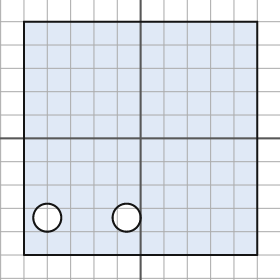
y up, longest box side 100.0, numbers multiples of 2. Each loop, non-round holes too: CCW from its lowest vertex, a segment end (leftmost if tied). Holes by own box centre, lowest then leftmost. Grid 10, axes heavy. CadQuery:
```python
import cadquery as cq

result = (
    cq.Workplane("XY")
    .moveTo(-50.0, -50.0)
    .lineTo(50.0, -50.0)
    .lineTo(50.0, 50.0)
    .lineTo(-50.0, 50.0)
    .close()
    .moveTo(-40.0, -34.0)
    .circle(6.0)
    .moveTo(-6.0, -34.0)
    .circle(6.0)
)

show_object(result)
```